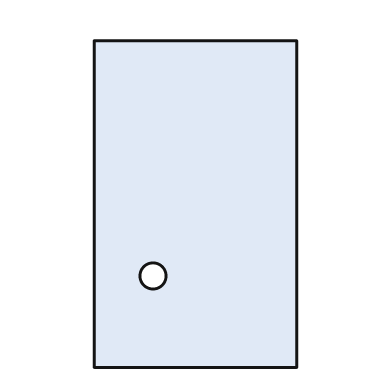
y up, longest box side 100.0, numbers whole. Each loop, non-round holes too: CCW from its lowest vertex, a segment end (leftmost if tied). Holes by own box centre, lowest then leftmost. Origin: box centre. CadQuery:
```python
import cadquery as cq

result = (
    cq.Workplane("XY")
    .moveTo(-31.0, -50.0)
    .lineTo(31.0, -50.0)
    .lineTo(31.0, 50.0)
    .lineTo(-31.0, 50.0)
    .close()
    .moveTo(-13.0, -22.0)
    .circle(4.0)
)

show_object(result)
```